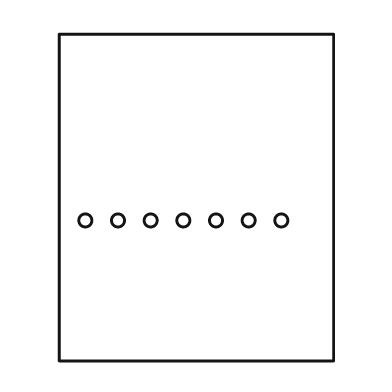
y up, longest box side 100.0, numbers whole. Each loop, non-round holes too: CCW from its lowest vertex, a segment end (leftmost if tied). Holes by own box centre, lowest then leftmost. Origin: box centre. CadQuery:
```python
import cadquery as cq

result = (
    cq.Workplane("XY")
    .moveTo(-42.0, -50.0)
    .lineTo(42.0, -50.0)
    .lineTo(42.0, 50.0)
    .lineTo(-42.0, 50.0)
    .close()
    .moveTo(-34.0, -7.0)
    .circle(2.0)
    .moveTo(-24.0, -7.0)
    .circle(2.0)
    .moveTo(-14.0, -7.0)
    .circle(2.0)
    .moveTo(-4.0, -7.0)
    .circle(2.0)
    .moveTo(6.0, -7.0)
    .circle(2.0)
    .moveTo(16.0, -7.0)
    .circle(2.0)
    .moveTo(26.0, -7.0)
    .circle(2.0)
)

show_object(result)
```